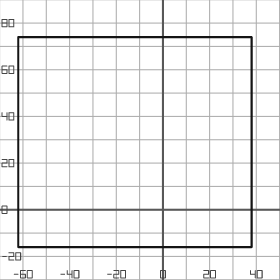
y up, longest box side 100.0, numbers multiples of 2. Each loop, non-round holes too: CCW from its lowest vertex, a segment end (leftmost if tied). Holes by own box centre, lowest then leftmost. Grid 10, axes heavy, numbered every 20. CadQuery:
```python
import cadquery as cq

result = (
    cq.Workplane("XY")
    .moveTo(-62.0, -16.0)
    .lineTo(38.0, -16.0)
    .lineTo(38.0, 74.0)
    .lineTo(-62.0, 74.0)
    .close()
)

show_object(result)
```